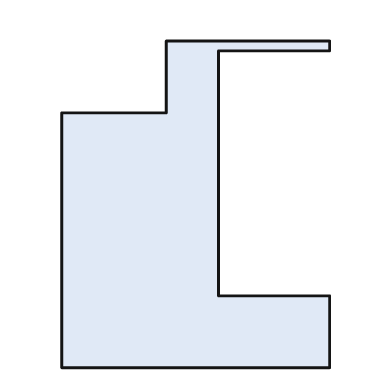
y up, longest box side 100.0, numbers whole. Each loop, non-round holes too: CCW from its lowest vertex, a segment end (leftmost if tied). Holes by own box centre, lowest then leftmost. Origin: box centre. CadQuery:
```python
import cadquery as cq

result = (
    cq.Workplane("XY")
    .moveTo(-41.0, -50.0)
    .lineTo(41.0, -50.0)
    .lineTo(41.0, -28.0)
    .lineTo(7.0, -28.0)
    .lineTo(7.0, 47.0)
    .lineTo(41.0, 47.0)
    .lineTo(41.0, 50.0)
    .lineTo(-9.0, 50.0)
    .lineTo(-9.0, 28.0)
    .lineTo(-41.0, 28.0)
    .close()
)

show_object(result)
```